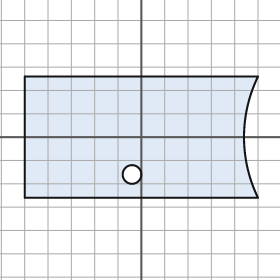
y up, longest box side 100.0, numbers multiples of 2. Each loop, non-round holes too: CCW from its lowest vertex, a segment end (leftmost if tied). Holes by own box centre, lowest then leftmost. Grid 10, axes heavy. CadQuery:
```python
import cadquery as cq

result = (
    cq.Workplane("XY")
    .moveTo(-50.0, -26.0)
    .lineTo(50.0, -26.0)
    .threePointArc((44.0, 0.0), (50.0, 26.0))
    .lineTo(-50.0, 26.0)
    .close()
    .moveTo(-4.0, -16.0)
    .circle(4.0)
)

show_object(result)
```